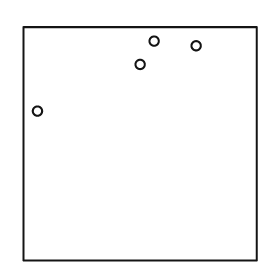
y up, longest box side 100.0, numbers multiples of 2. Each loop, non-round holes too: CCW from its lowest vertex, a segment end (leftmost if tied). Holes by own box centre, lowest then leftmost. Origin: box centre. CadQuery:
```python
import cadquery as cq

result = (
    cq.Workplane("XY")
    .moveTo(-50.0, -50.0)
    .lineTo(50.0, -50.0)
    .lineTo(50.0, 50.0)
    .lineTo(-50.0, 50.0)
    .close()
    .moveTo(-44.0, 14.0)
    .circle(2.0)
    .moveTo(0.0, 34.0)
    .circle(2.0)
    .moveTo(24.0, 42.0)
    .circle(2.0)
    .moveTo(6.0, 44.0)
    .circle(2.0)
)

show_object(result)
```